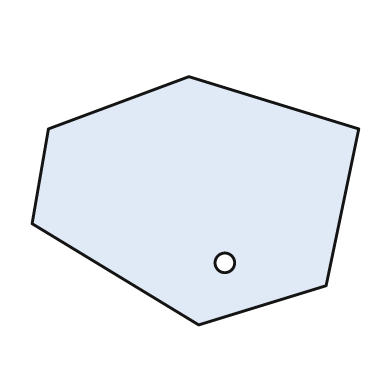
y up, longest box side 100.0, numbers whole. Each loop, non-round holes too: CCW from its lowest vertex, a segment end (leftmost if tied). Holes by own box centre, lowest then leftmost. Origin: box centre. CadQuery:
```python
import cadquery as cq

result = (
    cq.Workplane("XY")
    .moveTo(1.0, -38.0)
    .lineTo(40.0, -26.0)
    .lineTo(50.0, 22.0)
    .lineTo(-2.0, 38.0)
    .lineTo(-45.0, 22.0)
    .lineTo(-50.0, -7.0)
    .close()
    .moveTo(9.0, -19.0)
    .circle(3.0)
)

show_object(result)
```